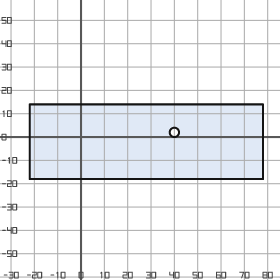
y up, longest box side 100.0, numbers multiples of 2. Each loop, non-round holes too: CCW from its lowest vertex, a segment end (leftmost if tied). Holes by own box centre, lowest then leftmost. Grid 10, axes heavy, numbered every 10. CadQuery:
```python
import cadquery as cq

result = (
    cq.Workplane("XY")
    .moveTo(-22.0, -18.0)
    .lineTo(78.0, -18.0)
    .lineTo(78.0, 14.0)
    .lineTo(-22.0, 14.0)
    .close()
    .moveTo(40.0, 2.0)
    .circle(2.0)
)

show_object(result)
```